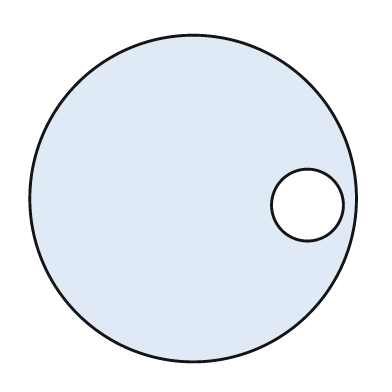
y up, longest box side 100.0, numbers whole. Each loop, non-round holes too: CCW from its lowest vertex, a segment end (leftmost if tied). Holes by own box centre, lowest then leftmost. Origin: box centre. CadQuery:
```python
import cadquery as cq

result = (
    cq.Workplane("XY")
    .moveTo(0.0, 0.0)
    .circle(50.0)
    .moveTo(35.0, -2.0)
    .circle(11.0)
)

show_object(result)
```